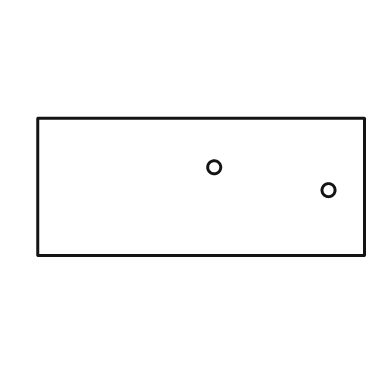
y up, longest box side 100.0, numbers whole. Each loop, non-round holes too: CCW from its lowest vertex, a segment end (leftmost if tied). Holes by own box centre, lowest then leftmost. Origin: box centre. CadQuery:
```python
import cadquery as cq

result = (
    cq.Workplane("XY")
    .moveTo(-50.0, -21.0)
    .lineTo(50.0, -21.0)
    .lineTo(50.0, 21.0)
    .lineTo(-50.0, 21.0)
    .close()
    .moveTo(39.0, -1.0)
    .circle(2.0)
    .moveTo(4.0, 6.0)
    .circle(2.0)
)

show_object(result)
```